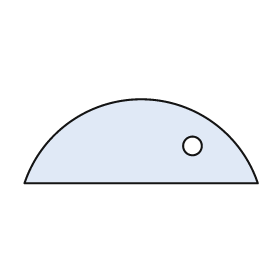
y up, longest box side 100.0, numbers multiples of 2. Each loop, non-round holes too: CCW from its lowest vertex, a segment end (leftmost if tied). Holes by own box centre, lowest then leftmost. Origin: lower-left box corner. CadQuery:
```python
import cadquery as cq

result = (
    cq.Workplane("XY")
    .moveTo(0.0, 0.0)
    .lineTo(100.0, 0.0)
    .threePointArc((50.0, 36.0), (0.0, 0.0))
    .close()
    .moveTo(72.0, 16.0)
    .circle(4.0)
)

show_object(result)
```